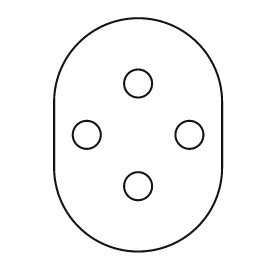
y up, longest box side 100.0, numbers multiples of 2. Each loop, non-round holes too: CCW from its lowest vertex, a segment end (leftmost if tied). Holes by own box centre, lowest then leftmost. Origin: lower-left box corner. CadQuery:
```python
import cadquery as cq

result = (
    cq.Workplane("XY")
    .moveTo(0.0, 36.0)
    .threePointArc((36.0, 0.0), (72.0, 36.0))
    .lineTo(72.0, 64.0)
    .threePointArc((36.0, 100.0), (0.0, 64.0))
    .close()
    .moveTo(36.0, 28.0)
    .circle(6.0)
    .moveTo(14.0, 50.0)
    .circle(6.0)
    .moveTo(58.0, 50.0)
    .circle(6.0)
    .moveTo(36.0, 72.0)
    .circle(6.0)
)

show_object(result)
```